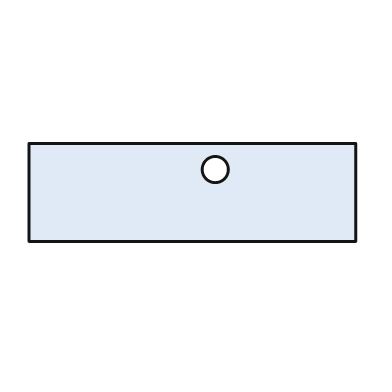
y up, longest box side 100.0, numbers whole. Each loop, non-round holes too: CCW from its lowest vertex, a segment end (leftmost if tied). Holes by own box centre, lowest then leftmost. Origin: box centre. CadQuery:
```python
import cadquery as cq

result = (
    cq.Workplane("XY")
    .moveTo(-50.0, -15.0)
    .lineTo(50.0, -15.0)
    .lineTo(50.0, 15.0)
    .lineTo(-50.0, 15.0)
    .close()
    .moveTo(7.0, 7.0)
    .circle(4.0)
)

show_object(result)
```